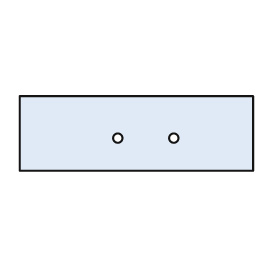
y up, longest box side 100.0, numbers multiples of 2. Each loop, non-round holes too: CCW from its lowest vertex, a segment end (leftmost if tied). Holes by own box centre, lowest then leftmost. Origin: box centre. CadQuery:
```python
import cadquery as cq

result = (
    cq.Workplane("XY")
    .moveTo(-50.0, -16.0)
    .lineTo(50.0, -16.0)
    .lineTo(50.0, 16.0)
    .lineTo(-50.0, 16.0)
    .close()
    .moveTo(-8.0, -2.0)
    .circle(2.0)
    .moveTo(16.0, -2.0)
    .circle(2.0)
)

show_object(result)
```